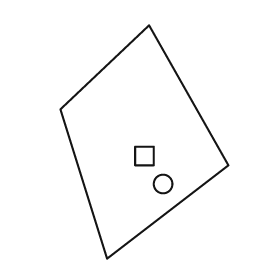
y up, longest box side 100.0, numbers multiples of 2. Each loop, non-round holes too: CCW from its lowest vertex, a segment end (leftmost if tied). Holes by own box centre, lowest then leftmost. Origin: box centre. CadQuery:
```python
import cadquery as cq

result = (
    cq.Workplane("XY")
    .moveTo(-16.0, -50.0)
    .lineTo(36.0, -10.0)
    .lineTo(2.0, 50.0)
    .lineTo(-36.0, 14.0)
    .close()
    .moveTo(8.0, -18.0)
    .circle(4.0)
    .moveTo(-4.0, -10.0)
    .lineTo(4.0, -10.0)
    .lineTo(4.0, -2.0)
    .lineTo(-4.0, -2.0)
    .close()
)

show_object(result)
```